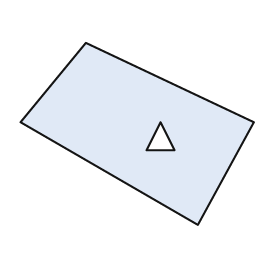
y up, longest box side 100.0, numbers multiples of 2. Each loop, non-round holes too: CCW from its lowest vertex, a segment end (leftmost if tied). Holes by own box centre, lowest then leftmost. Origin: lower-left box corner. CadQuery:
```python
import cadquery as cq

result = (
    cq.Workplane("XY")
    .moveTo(76.0, 0.0)
    .lineTo(100.0, 44.0)
    .lineTo(28.0, 78.0)
    .lineTo(0.0, 44.0)
    .close()
    .moveTo(54.0, 32.0)
    .lineTo(66.0, 32.0)
    .lineTo(60.0, 44.0)
    .close()
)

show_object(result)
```